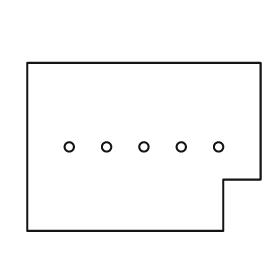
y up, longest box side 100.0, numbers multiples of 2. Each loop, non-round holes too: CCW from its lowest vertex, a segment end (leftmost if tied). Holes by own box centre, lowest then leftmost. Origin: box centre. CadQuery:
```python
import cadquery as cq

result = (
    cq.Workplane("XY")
    .moveTo(-50.0, -36.0)
    .lineTo(34.0, -36.0)
    .lineTo(34.0, -14.0)
    .lineTo(50.0, -14.0)
    .lineTo(50.0, 36.0)
    .lineTo(-50.0, 36.0)
    .close()
    .moveTo(-32.0, 0.0)
    .circle(2.0)
    .moveTo(-16.0, 0.0)
    .circle(2.0)
    .moveTo(0.0, 0.0)
    .circle(2.0)
    .moveTo(16.0, 0.0)
    .circle(2.0)
    .moveTo(32.0, 0.0)
    .circle(2.0)
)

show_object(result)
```